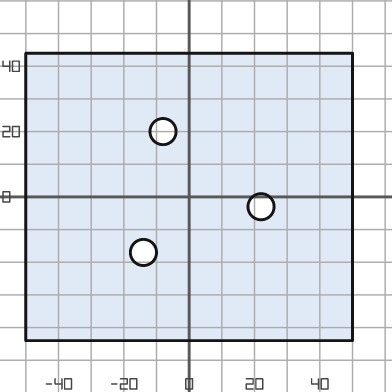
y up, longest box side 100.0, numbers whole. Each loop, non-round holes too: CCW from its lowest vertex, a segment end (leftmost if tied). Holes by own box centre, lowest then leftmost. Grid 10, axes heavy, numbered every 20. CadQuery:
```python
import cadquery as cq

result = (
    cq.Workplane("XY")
    .moveTo(-50.0, -44.0)
    .lineTo(50.0, -44.0)
    .lineTo(50.0, 44.0)
    .lineTo(-50.0, 44.0)
    .close()
    .moveTo(-14.0, -17.0)
    .circle(4.0)
    .moveTo(22.0, -3.0)
    .circle(4.0)
    .moveTo(-8.0, 20.0)
    .circle(4.0)
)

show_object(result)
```